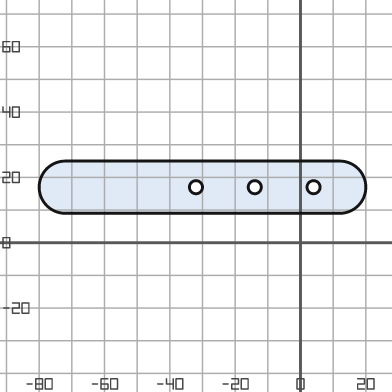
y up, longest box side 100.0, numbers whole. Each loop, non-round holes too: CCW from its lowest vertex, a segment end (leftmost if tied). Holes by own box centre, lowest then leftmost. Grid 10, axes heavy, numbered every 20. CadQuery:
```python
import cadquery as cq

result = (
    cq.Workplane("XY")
    .moveTo(-72.0, 9.0)
    .lineTo(12.0, 9.0)
    .threePointArc((20.0, 17.0), (12.0, 25.0))
    .lineTo(-72.0, 25.0)
    .threePointArc((-80.0, 17.0), (-72.0, 9.0))
    .close()
    .moveTo(-32.0, 17.0)
    .circle(2.0)
    .moveTo(-14.0, 17.0)
    .circle(2.0)
    .moveTo(4.0, 17.0)
    .circle(2.0)
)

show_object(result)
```